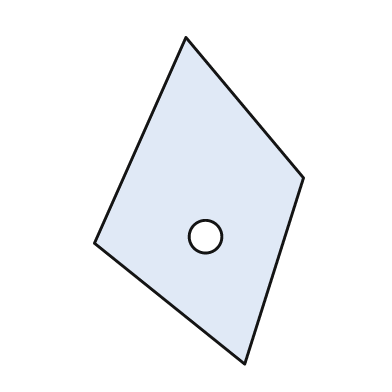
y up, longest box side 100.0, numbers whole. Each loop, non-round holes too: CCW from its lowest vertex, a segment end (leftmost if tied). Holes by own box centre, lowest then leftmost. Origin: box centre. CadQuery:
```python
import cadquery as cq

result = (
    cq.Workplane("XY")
    .moveTo(14.0, -50.0)
    .lineTo(32.0, 7.0)
    .lineTo(-4.0, 50.0)
    .lineTo(-32.0, -13.0)
    .close()
    .moveTo(2.0, -11.0)
    .circle(5.0)
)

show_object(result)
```